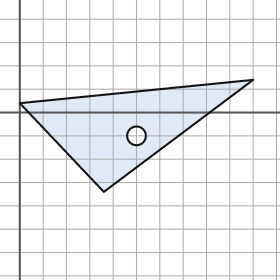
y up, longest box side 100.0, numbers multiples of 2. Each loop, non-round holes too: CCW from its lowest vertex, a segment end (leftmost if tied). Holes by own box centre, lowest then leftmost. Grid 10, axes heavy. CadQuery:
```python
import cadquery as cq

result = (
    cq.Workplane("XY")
    .moveTo(36.0, -34.0)
    .lineTo(100.0, 14.0)
    .lineTo(0.0, 4.0)
    .close()
    .moveTo(50.0, -10.0)
    .circle(4.0)
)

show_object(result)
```